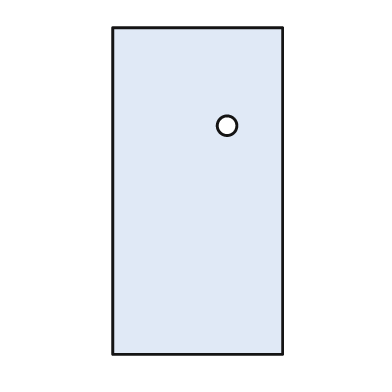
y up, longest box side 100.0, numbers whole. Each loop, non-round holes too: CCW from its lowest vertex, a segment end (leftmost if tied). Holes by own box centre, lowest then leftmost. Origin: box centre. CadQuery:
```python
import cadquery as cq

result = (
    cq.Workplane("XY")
    .moveTo(-26.0, -50.0)
    .lineTo(26.0, -50.0)
    .lineTo(26.0, 50.0)
    .lineTo(-26.0, 50.0)
    .close()
    .moveTo(9.0, 20.0)
    .circle(3.0)
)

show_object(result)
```